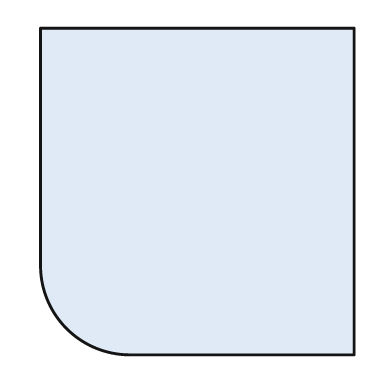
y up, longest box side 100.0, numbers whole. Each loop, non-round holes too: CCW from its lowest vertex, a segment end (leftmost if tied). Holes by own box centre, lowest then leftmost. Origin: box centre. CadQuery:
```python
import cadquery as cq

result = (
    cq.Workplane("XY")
    .moveTo(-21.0, -50.0)
    .lineTo(48.0, -50.0)
    .lineTo(48.0, 50.0)
    .lineTo(-48.0, 50.0)
    .lineTo(-48.0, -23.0)
    .threePointArc((-40.0, -42.0), (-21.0, -50.0))
    .close()
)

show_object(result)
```